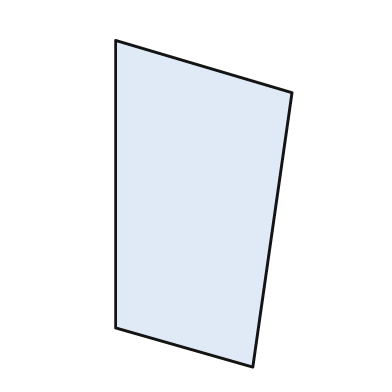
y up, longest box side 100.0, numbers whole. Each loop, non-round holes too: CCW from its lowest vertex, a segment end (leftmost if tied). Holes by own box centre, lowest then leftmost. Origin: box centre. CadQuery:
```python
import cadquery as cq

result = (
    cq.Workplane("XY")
    .moveTo(15.0, -50.0)
    .lineTo(27.0, 34.0)
    .lineTo(-27.0, 50.0)
    .lineTo(-27.0, -38.0)
    .close()
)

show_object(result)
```